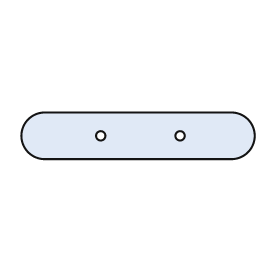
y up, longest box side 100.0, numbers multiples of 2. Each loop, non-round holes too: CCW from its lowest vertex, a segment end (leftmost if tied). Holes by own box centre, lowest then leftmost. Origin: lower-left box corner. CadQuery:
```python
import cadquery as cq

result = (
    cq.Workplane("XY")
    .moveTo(10.0, 0.0)
    .lineTo(90.0, 0.0)
    .threePointArc((100.0, 10.0), (90.0, 20.0))
    .lineTo(10.0, 20.0)
    .threePointArc((0.0, 10.0), (10.0, 0.0))
    .close()
    .moveTo(34.0, 10.0)
    .circle(2.0)
    .moveTo(68.0, 10.0)
    .circle(2.0)
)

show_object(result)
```